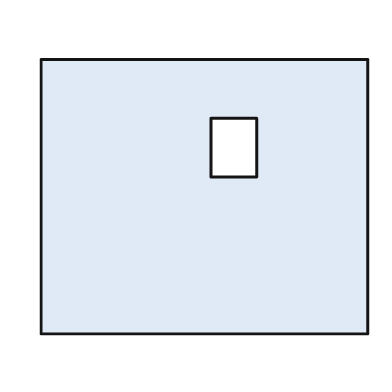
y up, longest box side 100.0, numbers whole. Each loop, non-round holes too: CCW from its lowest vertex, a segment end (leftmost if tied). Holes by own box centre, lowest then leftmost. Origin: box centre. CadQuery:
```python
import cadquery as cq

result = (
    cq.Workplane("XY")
    .moveTo(-50.0, -42.0)
    .lineTo(50.0, -42.0)
    .lineTo(50.0, 42.0)
    .lineTo(-50.0, 42.0)
    .close()
    .moveTo(2.0, 6.0)
    .lineTo(16.0, 6.0)
    .lineTo(16.0, 24.0)
    .lineTo(2.0, 24.0)
    .close()
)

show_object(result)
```